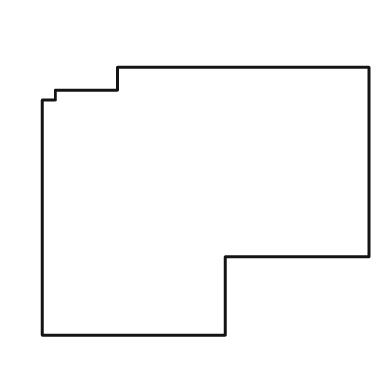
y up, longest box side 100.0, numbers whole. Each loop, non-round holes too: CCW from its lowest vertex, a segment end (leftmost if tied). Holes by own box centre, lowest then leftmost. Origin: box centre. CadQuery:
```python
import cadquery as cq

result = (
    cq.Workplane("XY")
    .moveTo(-50.0, -41.0)
    .lineTo(6.0, -41.0)
    .lineTo(6.0, -17.0)
    .lineTo(50.0, -17.0)
    .lineTo(50.0, 41.0)
    .lineTo(-27.0, 41.0)
    .lineTo(-27.0, 34.0)
    .lineTo(-46.0, 34.0)
    .lineTo(-46.0, 31.0)
    .lineTo(-50.0, 31.0)
    .close()
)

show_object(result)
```